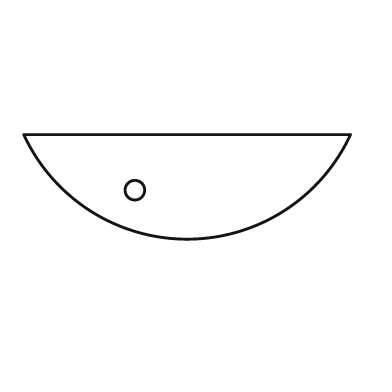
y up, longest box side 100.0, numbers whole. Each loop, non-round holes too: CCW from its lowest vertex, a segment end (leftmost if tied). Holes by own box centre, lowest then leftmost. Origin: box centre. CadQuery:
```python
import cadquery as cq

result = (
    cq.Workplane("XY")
    .moveTo(-50.0, 16.0)
    .threePointArc((0.0, -16.0), (50.0, 16.0))
    .close()
    .moveTo(-16.0, -1.0)
    .circle(3.0)
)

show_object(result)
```